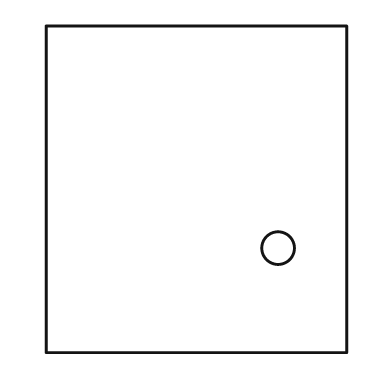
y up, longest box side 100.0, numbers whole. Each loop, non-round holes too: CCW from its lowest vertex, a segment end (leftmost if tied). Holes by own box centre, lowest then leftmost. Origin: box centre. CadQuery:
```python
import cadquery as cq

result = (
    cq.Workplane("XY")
    .moveTo(-46.0, -50.0)
    .lineTo(46.0, -50.0)
    .lineTo(46.0, 50.0)
    .lineTo(-46.0, 50.0)
    .close()
    .moveTo(25.0, -18.0)
    .circle(5.0)
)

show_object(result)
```